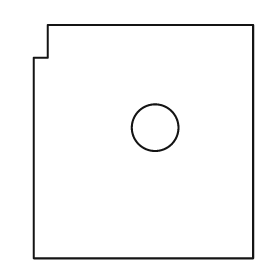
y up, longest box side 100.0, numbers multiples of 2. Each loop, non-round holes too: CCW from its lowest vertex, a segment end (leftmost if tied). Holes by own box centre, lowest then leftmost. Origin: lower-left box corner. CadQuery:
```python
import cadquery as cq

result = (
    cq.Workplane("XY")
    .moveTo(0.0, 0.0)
    .lineTo(94.0, 0.0)
    .lineTo(94.0, 100.0)
    .lineTo(6.0, 100.0)
    .lineTo(6.0, 86.0)
    .lineTo(0.0, 86.0)
    .close()
    .moveTo(52.0, 56.0)
    .circle(10.0)
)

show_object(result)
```